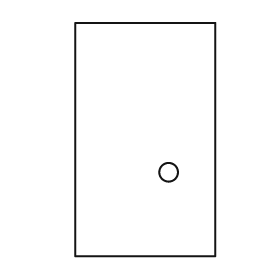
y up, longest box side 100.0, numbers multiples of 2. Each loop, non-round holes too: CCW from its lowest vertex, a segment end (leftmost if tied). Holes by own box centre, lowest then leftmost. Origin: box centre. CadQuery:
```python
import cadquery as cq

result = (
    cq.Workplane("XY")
    .moveTo(-30.0, -50.0)
    .lineTo(30.0, -50.0)
    .lineTo(30.0, 50.0)
    .lineTo(-30.0, 50.0)
    .close()
    .moveTo(10.0, -14.0)
    .circle(4.0)
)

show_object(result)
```